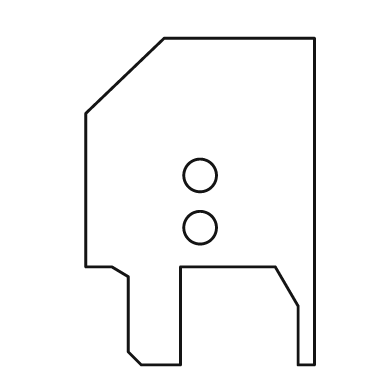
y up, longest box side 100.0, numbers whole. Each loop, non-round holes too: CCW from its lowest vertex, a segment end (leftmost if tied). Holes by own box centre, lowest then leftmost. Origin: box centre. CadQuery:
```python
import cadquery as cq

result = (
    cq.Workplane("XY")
    .moveTo(-18.0, -50.0)
    .lineTo(-6.0, -50.0)
    .lineTo(-6.0, -20.0)
    .lineTo(23.0, -20.0)
    .lineTo(30.0, -32.0)
    .lineTo(30.0, -50.0)
    .lineTo(35.0, -50.0)
    .lineTo(35.0, 50.0)
    .lineTo(-11.0, 50.0)
    .lineTo(-35.0, 27.0)
    .lineTo(-35.0, -20.0)
    .lineTo(-27.0, -20.0)
    .lineTo(-22.0, -23.0)
    .lineTo(-22.0, -46.0)
    .close()
    .moveTo(0.0, -8.0)
    .circle(5.0)
    .moveTo(0.0, 8.0)
    .circle(5.0)
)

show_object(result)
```